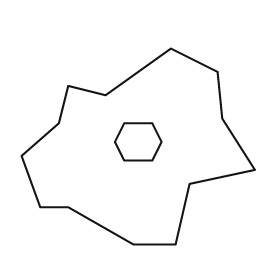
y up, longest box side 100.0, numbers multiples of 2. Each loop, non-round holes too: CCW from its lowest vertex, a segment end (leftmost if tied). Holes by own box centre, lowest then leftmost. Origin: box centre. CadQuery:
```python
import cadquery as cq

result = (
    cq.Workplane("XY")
    .moveTo(-2.0, -42.0)
    .lineTo(16.0, -42.0)
    .lineTo(22.0, -16.0)
    .lineTo(50.0, -10.0)
    .lineTo(36.0, 12.0)
    .lineTo(34.0, 32.0)
    .lineTo(14.0, 42.0)
    .lineTo(-14.0, 22.0)
    .lineTo(-30.0, 26.0)
    .lineTo(-34.0, 10.0)
    .lineTo(-50.0, -4.0)
    .lineTo(-42.0, -26.0)
    .lineTo(-30.0, -26.0)
    .close()
    .moveTo(-6.0, -6.0)
    .lineTo(6.0, -6.0)
    .lineTo(10.0, 2.0)
    .lineTo(6.0, 10.0)
    .lineTo(-6.0, 10.0)
    .lineTo(-10.0, 2.0)
    .close()
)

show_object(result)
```